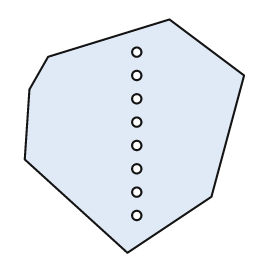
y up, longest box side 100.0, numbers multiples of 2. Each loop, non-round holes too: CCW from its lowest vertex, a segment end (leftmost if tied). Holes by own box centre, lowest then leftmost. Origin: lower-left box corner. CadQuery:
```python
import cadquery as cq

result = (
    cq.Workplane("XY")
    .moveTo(44.0, 0.0)
    .lineTo(80.0, 24.0)
    .lineTo(94.0, 76.0)
    .lineTo(62.0, 100.0)
    .lineTo(10.0, 84.0)
    .lineTo(2.0, 70.0)
    .lineTo(0.0, 40.0)
    .close()
    .moveTo(48.0, 16.0)
    .circle(2.0)
    .moveTo(48.0, 26.0)
    .circle(2.0)
    .moveTo(48.0, 36.0)
    .circle(2.0)
    .moveTo(48.0, 46.0)
    .circle(2.0)
    .moveTo(48.0, 56.0)
    .circle(2.0)
    .moveTo(48.0, 66.0)
    .circle(2.0)
    .moveTo(48.0, 76.0)
    .circle(2.0)
    .moveTo(48.0, 86.0)
    .circle(2.0)
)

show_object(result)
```